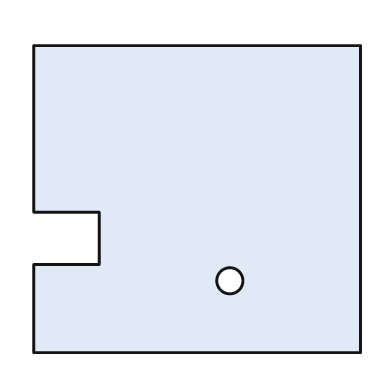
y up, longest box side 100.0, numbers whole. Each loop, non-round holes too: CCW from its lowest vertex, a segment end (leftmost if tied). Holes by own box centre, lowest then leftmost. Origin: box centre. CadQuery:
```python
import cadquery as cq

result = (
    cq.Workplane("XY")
    .moveTo(-50.0, -47.0)
    .lineTo(50.0, -47.0)
    .lineTo(50.0, 47.0)
    .lineTo(-50.0, 47.0)
    .lineTo(-50.0, -4.0)
    .lineTo(-30.0, -4.0)
    .lineTo(-30.0, -20.0)
    .lineTo(-50.0, -20.0)
    .close()
    .moveTo(10.0, -25.0)
    .circle(4.0)
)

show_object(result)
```